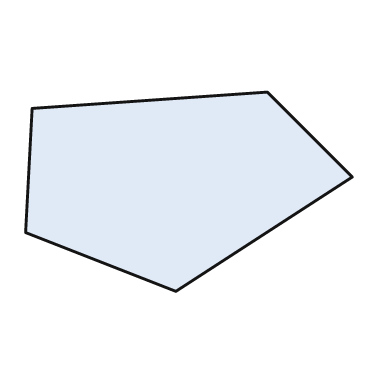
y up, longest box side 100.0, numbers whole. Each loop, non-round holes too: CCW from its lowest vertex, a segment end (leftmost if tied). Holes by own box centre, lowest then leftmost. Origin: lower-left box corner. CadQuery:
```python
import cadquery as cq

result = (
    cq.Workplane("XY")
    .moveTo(46.0, 0.0)
    .lineTo(100.0, 35.0)
    .lineTo(74.0, 61.0)
    .lineTo(2.0, 56.0)
    .lineTo(0.0, 18.0)
    .close()
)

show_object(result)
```